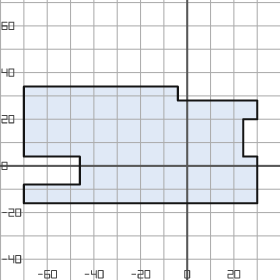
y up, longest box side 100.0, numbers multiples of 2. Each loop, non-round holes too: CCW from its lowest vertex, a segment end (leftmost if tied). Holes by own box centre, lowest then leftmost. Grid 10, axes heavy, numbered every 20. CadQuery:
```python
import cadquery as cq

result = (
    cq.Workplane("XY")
    .moveTo(-70.0, -16.0)
    .lineTo(30.0, -16.0)
    .lineTo(30.0, 4.0)
    .lineTo(24.0, 4.0)
    .lineTo(24.0, 20.0)
    .lineTo(30.0, 20.0)
    .lineTo(30.0, 28.0)
    .lineTo(-4.0, 28.0)
    .lineTo(-4.0, 34.0)
    .lineTo(-70.0, 34.0)
    .lineTo(-70.0, 4.0)
    .lineTo(-46.0, 4.0)
    .lineTo(-46.0, -8.0)
    .lineTo(-70.0, -8.0)
    .close()
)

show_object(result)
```